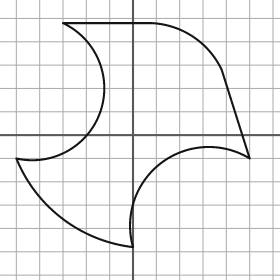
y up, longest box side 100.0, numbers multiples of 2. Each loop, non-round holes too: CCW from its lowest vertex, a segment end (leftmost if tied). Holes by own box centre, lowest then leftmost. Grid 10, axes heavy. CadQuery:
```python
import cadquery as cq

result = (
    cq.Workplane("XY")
    .moveTo(0.0, -48.0)
    .threePointArc((12.0, -12.0), (50.0, -10.0))
    .lineTo(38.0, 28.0)
    .threePointArc((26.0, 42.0), (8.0, 48.0))
    .lineTo(-30.0, 48.0)
    .threePointArc((-14.0, 10.0), (-50.0, -10.0))
    .threePointArc((-30.0, -36.0), (0.0, -48.0))
    .close()
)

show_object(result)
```